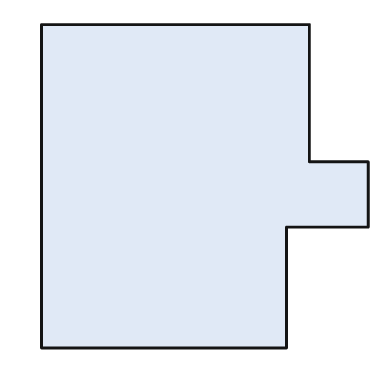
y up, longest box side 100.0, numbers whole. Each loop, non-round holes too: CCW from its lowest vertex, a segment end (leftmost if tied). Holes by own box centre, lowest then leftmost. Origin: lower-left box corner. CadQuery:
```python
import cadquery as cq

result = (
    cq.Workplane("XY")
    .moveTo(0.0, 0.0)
    .lineTo(75.0, 0.0)
    .lineTo(75.0, 37.0)
    .lineTo(100.0, 37.0)
    .lineTo(100.0, 57.0)
    .lineTo(82.0, 57.0)
    .lineTo(82.0, 99.0)
    .lineTo(0.0, 99.0)
    .close()
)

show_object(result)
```